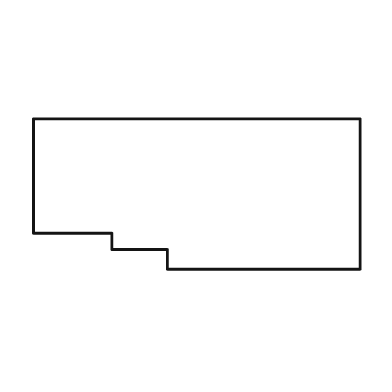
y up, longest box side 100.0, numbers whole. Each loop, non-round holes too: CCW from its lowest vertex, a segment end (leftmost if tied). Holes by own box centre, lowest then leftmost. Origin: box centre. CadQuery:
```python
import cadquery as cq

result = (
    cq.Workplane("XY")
    .moveTo(-9.0, -23.0)
    .lineTo(50.0, -23.0)
    .lineTo(50.0, 23.0)
    .lineTo(-50.0, 23.0)
    .lineTo(-50.0, -12.0)
    .lineTo(-26.0, -12.0)
    .lineTo(-26.0, -17.0)
    .lineTo(-9.0, -17.0)
    .close()
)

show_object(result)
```